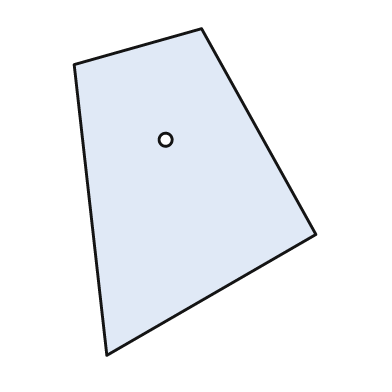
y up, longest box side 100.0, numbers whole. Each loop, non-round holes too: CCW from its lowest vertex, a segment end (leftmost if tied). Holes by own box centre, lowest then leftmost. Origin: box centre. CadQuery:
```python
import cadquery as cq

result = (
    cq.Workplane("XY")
    .moveTo(-27.0, -50.0)
    .lineTo(37.0, -13.0)
    .lineTo(2.0, 50.0)
    .lineTo(-37.0, 39.0)
    .close()
    .moveTo(-9.0, 16.0)
    .circle(2.0)
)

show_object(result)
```